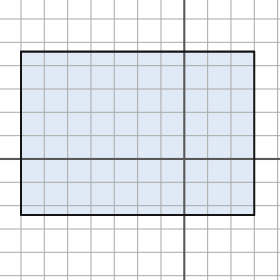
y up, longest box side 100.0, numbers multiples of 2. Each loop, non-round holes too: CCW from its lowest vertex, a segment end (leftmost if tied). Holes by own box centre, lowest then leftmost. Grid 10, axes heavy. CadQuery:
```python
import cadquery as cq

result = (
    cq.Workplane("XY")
    .moveTo(-70.0, -24.0)
    .lineTo(30.0, -24.0)
    .lineTo(30.0, 46.0)
    .lineTo(-70.0, 46.0)
    .close()
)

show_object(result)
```